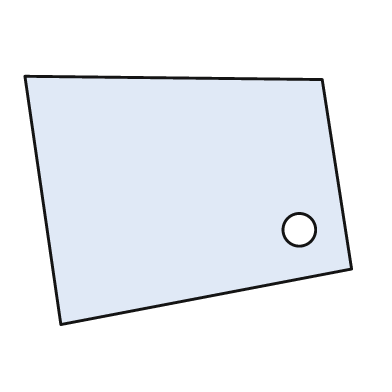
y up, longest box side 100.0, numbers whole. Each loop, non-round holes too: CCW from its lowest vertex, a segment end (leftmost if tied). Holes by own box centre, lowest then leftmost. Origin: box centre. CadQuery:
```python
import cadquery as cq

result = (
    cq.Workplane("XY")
    .moveTo(-39.0, -38.0)
    .lineTo(50.0, -21.0)
    .lineTo(41.0, 37.0)
    .lineTo(-50.0, 38.0)
    .close()
    .moveTo(34.0, -9.0)
    .circle(5.0)
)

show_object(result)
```